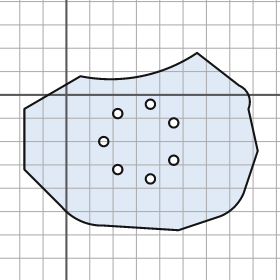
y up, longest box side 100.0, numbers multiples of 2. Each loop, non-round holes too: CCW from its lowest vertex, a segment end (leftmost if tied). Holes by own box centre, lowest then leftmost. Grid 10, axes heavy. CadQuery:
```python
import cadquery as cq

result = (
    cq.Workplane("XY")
    .moveTo(48.0, -58.0)
    .lineTo(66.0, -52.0)
    .threePointArc((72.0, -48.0), (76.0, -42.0))
    .lineTo(82.0, -24.0)
    .lineTo(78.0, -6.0)
    .threePointArc((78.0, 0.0), (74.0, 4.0))
    .lineTo(56.0, 18.0)
    .threePointArc((32.0, 8.0), (6.0, 8.0))
    .lineTo(-18.0, -6.0)
    .lineTo(-18.0, -32.0)
    .lineTo(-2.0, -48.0)
    .threePointArc((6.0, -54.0), (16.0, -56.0))
    .close()
    .moveTo(36.0, -36.0)
    .circle(2.0)
    .moveTo(22.0, -32.0)
    .circle(2.0)
    .moveTo(46.0, -28.0)
    .circle(2.0)
    .moveTo(16.0, -20.0)
    .circle(2.0)
    .moveTo(46.0, -12.0)
    .circle(2.0)
    .moveTo(22.0, -8.0)
    .circle(2.0)
    .moveTo(36.0, -4.0)
    .circle(2.0)
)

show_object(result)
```